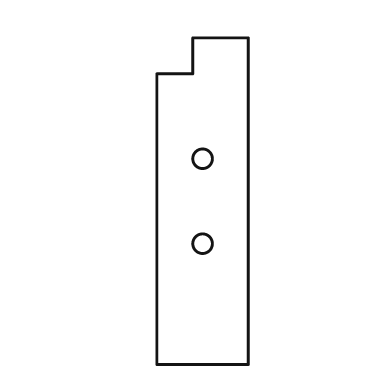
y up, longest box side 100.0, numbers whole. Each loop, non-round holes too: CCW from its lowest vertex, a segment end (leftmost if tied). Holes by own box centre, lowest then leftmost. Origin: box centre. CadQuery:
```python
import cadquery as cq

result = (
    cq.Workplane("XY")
    .moveTo(-14.0, -50.0)
    .lineTo(14.0, -50.0)
    .lineTo(14.0, 50.0)
    .lineTo(-3.0, 50.0)
    .lineTo(-3.0, 39.0)
    .lineTo(-14.0, 39.0)
    .close()
    .moveTo(0.0, -13.0)
    .circle(3.0)
    .moveTo(0.0, 13.0)
    .circle(3.0)
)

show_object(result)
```